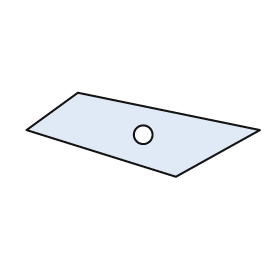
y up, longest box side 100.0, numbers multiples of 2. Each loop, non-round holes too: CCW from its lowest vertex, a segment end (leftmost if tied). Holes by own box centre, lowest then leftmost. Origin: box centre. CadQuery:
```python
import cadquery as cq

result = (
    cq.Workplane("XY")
    .moveTo(14.0, -18.0)
    .lineTo(50.0, 2.0)
    .lineTo(-28.0, 18.0)
    .lineTo(-50.0, 2.0)
    .close()
    .moveTo(0.0, 0.0)
    .circle(4.0)
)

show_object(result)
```